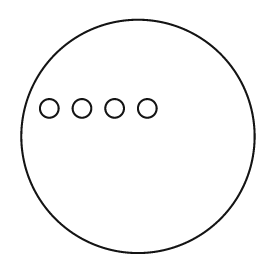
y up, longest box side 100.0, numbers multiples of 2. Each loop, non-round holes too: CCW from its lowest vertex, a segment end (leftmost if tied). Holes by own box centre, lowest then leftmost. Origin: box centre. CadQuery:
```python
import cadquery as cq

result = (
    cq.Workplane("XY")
    .moveTo(0.0, 0.0)
    .circle(50.0)
    .moveTo(-38.0, 12.0)
    .circle(4.0)
    .moveTo(-24.0, 12.0)
    .circle(4.0)
    .moveTo(-10.0, 12.0)
    .circle(4.0)
    .moveTo(4.0, 12.0)
    .circle(4.0)
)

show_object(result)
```